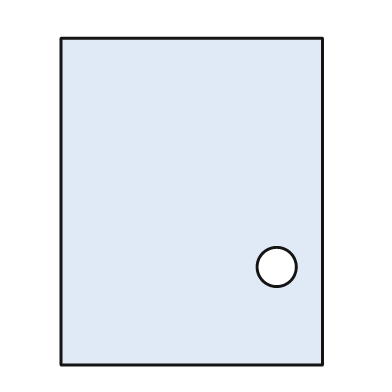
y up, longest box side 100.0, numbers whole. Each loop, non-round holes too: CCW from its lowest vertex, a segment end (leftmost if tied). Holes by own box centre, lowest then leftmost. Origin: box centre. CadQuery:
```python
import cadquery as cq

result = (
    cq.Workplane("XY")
    .moveTo(-40.0, -50.0)
    .lineTo(40.0, -50.0)
    .lineTo(40.0, 50.0)
    .lineTo(-40.0, 50.0)
    .close()
    .moveTo(26.0, -20.0)
    .circle(6.0)
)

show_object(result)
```